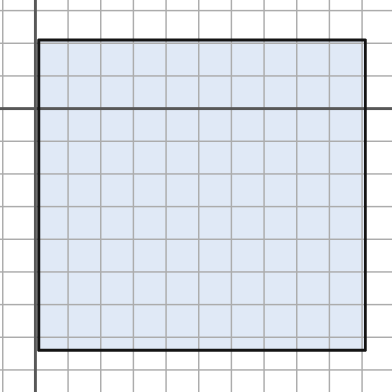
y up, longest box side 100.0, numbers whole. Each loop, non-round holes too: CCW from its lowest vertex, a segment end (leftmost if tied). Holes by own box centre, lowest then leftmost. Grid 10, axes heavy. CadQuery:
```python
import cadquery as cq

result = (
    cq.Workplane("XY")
    .moveTo(1.0, -74.0)
    .lineTo(101.0, -74.0)
    .lineTo(101.0, 21.0)
    .lineTo(1.0, 21.0)
    .close()
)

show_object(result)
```